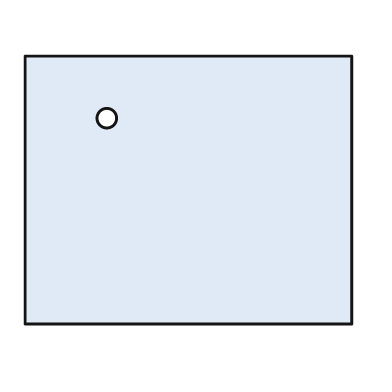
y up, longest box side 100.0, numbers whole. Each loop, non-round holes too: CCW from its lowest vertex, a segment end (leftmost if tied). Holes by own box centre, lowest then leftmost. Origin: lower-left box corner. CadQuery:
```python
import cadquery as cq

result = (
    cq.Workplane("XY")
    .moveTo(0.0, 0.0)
    .lineTo(100.0, 0.0)
    .lineTo(100.0, 82.0)
    .lineTo(0.0, 82.0)
    .close()
    .moveTo(25.0, 63.0)
    .circle(3.0)
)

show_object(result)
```